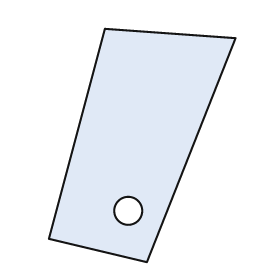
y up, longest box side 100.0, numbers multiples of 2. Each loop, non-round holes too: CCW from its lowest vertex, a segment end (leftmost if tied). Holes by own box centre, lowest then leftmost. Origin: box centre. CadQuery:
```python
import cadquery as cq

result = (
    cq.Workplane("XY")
    .moveTo(2.0, -50.0)
    .lineTo(40.0, 46.0)
    .lineTo(-16.0, 50.0)
    .lineTo(-40.0, -40.0)
    .close()
    .moveTo(-6.0, -28.0)
    .circle(6.0)
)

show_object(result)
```